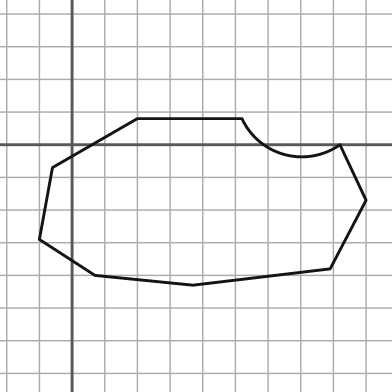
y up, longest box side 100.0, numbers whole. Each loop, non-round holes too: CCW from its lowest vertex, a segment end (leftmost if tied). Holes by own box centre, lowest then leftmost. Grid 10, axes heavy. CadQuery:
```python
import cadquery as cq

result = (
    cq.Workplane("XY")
    .moveTo(37.0, -43.0)
    .lineTo(79.0, -38.0)
    .lineTo(90.0, -17.0)
    .lineTo(82.0, 0.0)
    .threePointArc((65.0, -3.0), (52.0, 8.0))
    .lineTo(20.0, 8.0)
    .lineTo(-6.0, -7.0)
    .lineTo(-10.0, -29.0)
    .lineTo(7.0, -40.0)
    .close()
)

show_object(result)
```